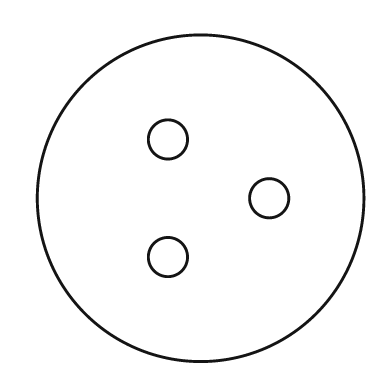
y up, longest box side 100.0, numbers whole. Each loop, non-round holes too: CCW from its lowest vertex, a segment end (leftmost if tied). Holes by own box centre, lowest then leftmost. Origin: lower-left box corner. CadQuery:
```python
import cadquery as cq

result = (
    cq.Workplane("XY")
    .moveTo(50.0, 50.0)
    .circle(50.0)
    .moveTo(40.0, 32.0)
    .circle(6.0)
    .moveTo(71.0, 50.0)
    .circle(6.0)
    .moveTo(40.0, 68.0)
    .circle(6.0)
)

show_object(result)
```